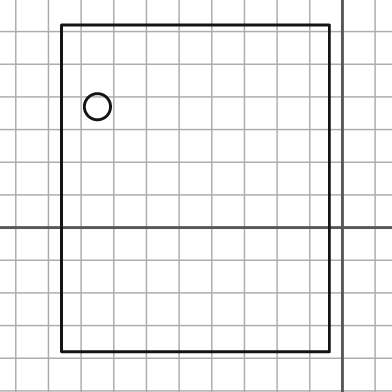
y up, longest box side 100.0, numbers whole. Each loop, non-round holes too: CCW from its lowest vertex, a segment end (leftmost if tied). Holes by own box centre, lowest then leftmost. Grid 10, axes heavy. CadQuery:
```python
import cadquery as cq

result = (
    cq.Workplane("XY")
    .moveTo(-86.0, -38.0)
    .lineTo(-4.0, -38.0)
    .lineTo(-4.0, 62.0)
    .lineTo(-86.0, 62.0)
    .close()
    .moveTo(-75.0, 37.0)
    .circle(4.0)
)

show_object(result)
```